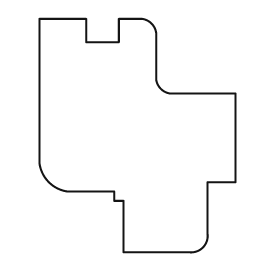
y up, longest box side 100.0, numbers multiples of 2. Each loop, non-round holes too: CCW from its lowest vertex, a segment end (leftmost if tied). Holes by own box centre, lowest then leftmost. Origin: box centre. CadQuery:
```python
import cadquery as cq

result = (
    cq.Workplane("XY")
    .moveTo(-6.0, -50.0)
    .lineTo(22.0, -50.0)
    .threePointArc((28.0, -48.0), (30.0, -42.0))
    .lineTo(30.0, -20.0)
    .lineTo(42.0, -20.0)
    .lineTo(42.0, 18.0)
    .lineTo(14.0, 18.0)
    .threePointArc((10.0, 20.0), (8.0, 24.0))
    .lineTo(8.0, 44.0)
    .threePointArc((6.0, 48.0), (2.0, 50.0))
    .lineTo(-8.0, 50.0)
    .lineTo(-8.0, 40.0)
    .lineTo(-22.0, 40.0)
    .lineTo(-22.0, 50.0)
    .lineTo(-42.0, 50.0)
    .lineTo(-42.0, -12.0)
    .threePointArc((-38.0, -20.0), (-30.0, -24.0))
    .lineTo(-10.0, -24.0)
    .lineTo(-10.0, -28.0)
    .lineTo(-6.0, -28.0)
    .close()
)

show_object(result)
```